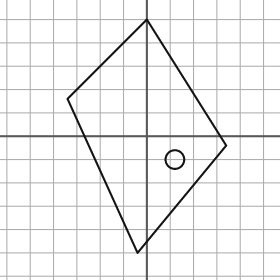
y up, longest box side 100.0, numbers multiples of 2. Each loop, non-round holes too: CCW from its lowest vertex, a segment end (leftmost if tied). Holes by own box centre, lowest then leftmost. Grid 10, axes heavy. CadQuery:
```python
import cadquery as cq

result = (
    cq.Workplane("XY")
    .moveTo(-4.0, -50.0)
    .lineTo(34.0, -4.0)
    .lineTo(0.0, 50.0)
    .lineTo(-34.0, 16.0)
    .close()
    .moveTo(12.0, -10.0)
    .circle(4.0)
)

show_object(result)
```